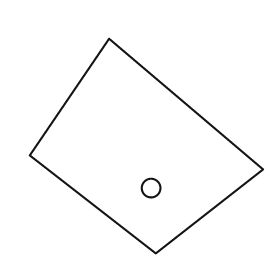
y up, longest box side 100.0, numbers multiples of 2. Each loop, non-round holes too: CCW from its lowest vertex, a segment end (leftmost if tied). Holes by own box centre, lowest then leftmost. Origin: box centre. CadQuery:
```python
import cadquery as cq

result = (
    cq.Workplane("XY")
    .moveTo(4.0, -46.0)
    .lineTo(50.0, -10.0)
    .lineTo(-16.0, 46.0)
    .lineTo(-50.0, -4.0)
    .close()
    .moveTo(2.0, -18.0)
    .circle(4.0)
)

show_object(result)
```